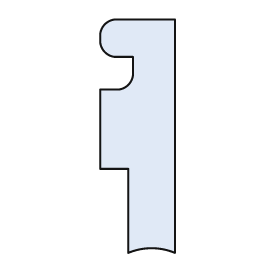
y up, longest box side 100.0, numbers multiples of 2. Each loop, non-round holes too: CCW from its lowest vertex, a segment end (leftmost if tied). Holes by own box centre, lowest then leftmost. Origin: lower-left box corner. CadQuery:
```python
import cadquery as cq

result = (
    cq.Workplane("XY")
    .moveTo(12.0, 0.0)
    .threePointArc((22.0, 2.0), (32.0, 0.0))
    .lineTo(32.0, 100.0)
    .lineTo(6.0, 100.0)
    .threePointArc((2.0, 98.0), (0.0, 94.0))
    .lineTo(0.0, 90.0)
    .threePointArc((2.0, 86.0), (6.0, 84.0))
    .lineTo(14.0, 84.0)
    .lineTo(14.0, 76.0)
    .threePointArc((12.0, 72.0), (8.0, 70.0))
    .lineTo(0.0, 70.0)
    .lineTo(0.0, 36.0)
    .lineTo(12.0, 36.0)
    .close()
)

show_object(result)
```